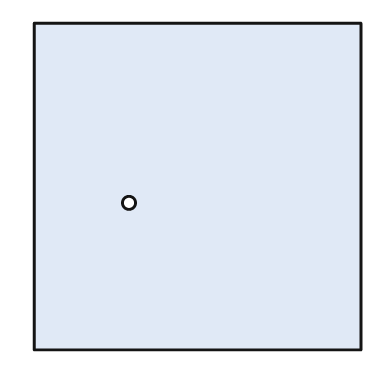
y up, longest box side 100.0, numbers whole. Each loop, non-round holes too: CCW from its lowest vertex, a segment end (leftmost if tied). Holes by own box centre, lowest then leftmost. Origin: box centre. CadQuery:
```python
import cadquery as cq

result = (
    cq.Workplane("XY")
    .moveTo(-50.0, -50.0)
    .lineTo(50.0, -50.0)
    .lineTo(50.0, 50.0)
    .lineTo(-50.0, 50.0)
    .close()
    .moveTo(-21.0, -5.0)
    .circle(2.0)
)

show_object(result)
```